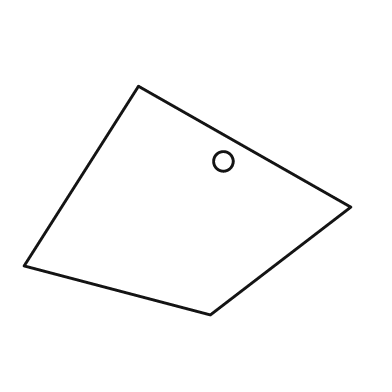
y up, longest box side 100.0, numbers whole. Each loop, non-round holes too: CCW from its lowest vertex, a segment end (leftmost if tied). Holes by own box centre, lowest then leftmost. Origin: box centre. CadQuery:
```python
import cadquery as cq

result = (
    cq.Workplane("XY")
    .moveTo(7.0, -35.0)
    .lineTo(50.0, -2.0)
    .lineTo(-15.0, 35.0)
    .lineTo(-50.0, -20.0)
    .close()
    .moveTo(11.0, 12.0)
    .circle(3.0)
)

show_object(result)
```